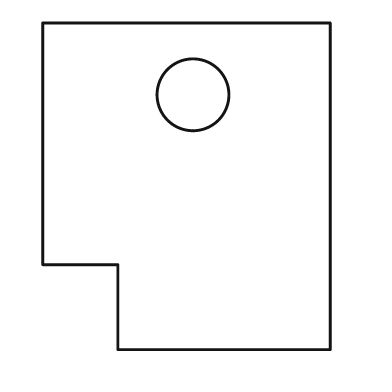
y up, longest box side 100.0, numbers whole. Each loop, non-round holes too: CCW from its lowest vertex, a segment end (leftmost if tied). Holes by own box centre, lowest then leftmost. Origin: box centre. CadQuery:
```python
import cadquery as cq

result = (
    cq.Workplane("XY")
    .moveTo(-21.0, -50.0)
    .lineTo(44.0, -50.0)
    .lineTo(44.0, 50.0)
    .lineTo(-44.0, 50.0)
    .lineTo(-44.0, -24.0)
    .lineTo(-21.0, -24.0)
    .close()
    .moveTo(2.0, 28.0)
    .circle(11.0)
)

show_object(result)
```